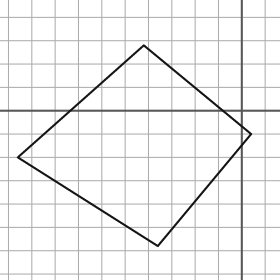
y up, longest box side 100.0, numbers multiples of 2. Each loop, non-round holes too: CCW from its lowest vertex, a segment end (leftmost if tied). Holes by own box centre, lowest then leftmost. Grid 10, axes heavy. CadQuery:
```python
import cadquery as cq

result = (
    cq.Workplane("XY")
    .moveTo(-36.0, -58.0)
    .lineTo(4.0, -10.0)
    .lineTo(-42.0, 28.0)
    .lineTo(-96.0, -20.0)
    .close()
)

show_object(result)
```